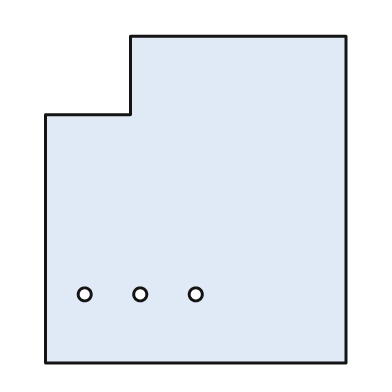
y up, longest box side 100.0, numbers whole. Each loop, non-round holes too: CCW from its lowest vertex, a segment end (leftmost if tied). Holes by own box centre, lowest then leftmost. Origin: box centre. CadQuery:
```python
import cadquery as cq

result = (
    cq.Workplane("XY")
    .moveTo(-46.0, -50.0)
    .lineTo(46.0, -50.0)
    .lineTo(46.0, 50.0)
    .lineTo(-20.0, 50.0)
    .lineTo(-20.0, 26.0)
    .lineTo(-46.0, 26.0)
    .close()
    .moveTo(-34.0, -29.0)
    .circle(2.0)
    .moveTo(-17.0, -29.0)
    .circle(2.0)
    .moveTo(0.0, -29.0)
    .circle(2.0)
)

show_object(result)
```